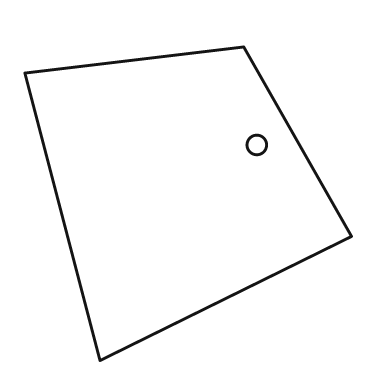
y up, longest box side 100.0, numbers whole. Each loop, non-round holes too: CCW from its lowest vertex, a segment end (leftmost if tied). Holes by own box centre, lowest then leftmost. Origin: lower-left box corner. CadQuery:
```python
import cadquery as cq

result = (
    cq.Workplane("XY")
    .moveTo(23.0, 0.0)
    .lineTo(100.0, 38.0)
    .lineTo(67.0, 96.0)
    .lineTo(0.0, 88.0)
    .close()
    .moveTo(71.0, 66.0)
    .circle(3.0)
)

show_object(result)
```